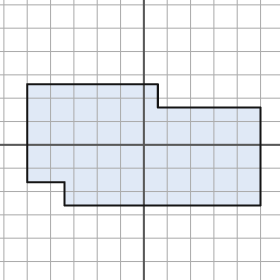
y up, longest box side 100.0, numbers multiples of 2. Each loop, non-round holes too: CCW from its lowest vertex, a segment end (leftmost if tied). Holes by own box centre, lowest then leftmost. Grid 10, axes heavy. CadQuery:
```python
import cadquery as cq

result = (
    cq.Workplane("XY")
    .moveTo(-34.0, -26.0)
    .lineTo(50.0, -26.0)
    .lineTo(50.0, 16.0)
    .lineTo(6.0, 16.0)
    .lineTo(6.0, 26.0)
    .lineTo(-50.0, 26.0)
    .lineTo(-50.0, -16.0)
    .lineTo(-34.0, -16.0)
    .close()
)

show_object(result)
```